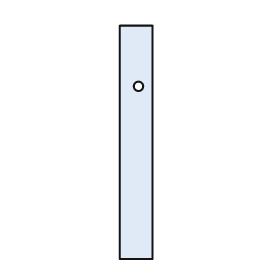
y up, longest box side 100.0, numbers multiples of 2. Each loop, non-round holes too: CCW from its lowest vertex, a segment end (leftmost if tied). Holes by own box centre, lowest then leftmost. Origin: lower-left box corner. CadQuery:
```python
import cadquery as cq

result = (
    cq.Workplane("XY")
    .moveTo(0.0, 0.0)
    .lineTo(14.0, 0.0)
    .lineTo(14.0, 100.0)
    .lineTo(0.0, 100.0)
    .close()
    .moveTo(8.0, 74.0)
    .circle(2.0)
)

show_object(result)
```